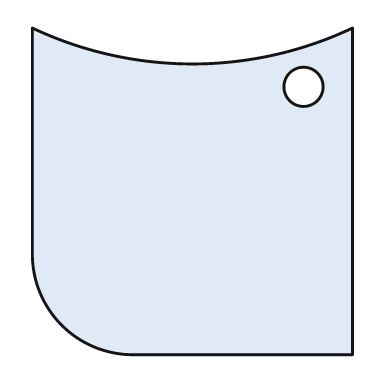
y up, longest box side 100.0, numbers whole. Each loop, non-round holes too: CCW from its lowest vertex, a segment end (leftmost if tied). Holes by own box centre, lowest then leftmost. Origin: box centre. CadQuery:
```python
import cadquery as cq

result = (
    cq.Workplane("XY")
    .moveTo(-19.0, -50.0)
    .lineTo(49.0, -50.0)
    .lineTo(49.0, 50.0)
    .threePointArc((0.0, 39.0), (-49.0, 50.0))
    .lineTo(-49.0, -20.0)
    .threePointArc((-40.0, -41.0), (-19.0, -50.0))
    .close()
    .moveTo(34.0, 32.0)
    .circle(6.0)
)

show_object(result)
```